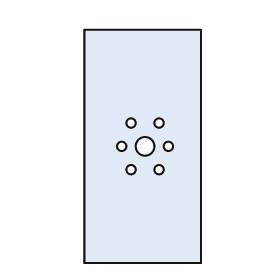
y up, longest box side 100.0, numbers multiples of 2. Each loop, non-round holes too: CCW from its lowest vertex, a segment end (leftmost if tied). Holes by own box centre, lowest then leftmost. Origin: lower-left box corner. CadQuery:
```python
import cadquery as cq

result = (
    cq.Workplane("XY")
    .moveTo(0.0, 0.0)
    .lineTo(50.0, 0.0)
    .lineTo(50.0, 100.0)
    .lineTo(0.0, 100.0)
    .close()
    .moveTo(20.0, 40.0)
    .circle(2.0)
    .moveTo(32.0, 40.0)
    .circle(2.0)
    .moveTo(16.0, 50.0)
    .circle(2.0)
    .moveTo(26.0, 50.0)
    .circle(4.0)
    .moveTo(36.0, 50.0)
    .circle(2.0)
    .moveTo(20.0, 60.0)
    .circle(2.0)
    .moveTo(32.0, 60.0)
    .circle(2.0)
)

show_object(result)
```